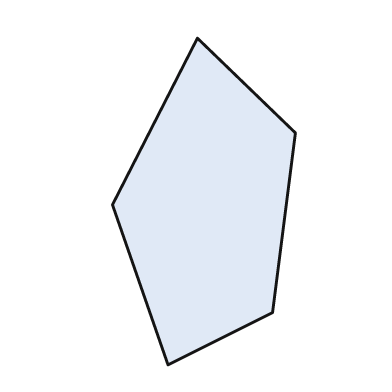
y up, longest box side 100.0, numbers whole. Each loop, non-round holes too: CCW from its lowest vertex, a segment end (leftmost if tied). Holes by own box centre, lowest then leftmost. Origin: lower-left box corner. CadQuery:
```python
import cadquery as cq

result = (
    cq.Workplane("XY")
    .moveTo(17.0, 0.0)
    .lineTo(49.0, 16.0)
    .lineTo(56.0, 71.0)
    .lineTo(26.0, 100.0)
    .lineTo(0.0, 49.0)
    .close()
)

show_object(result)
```